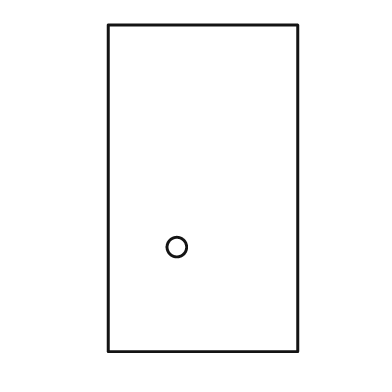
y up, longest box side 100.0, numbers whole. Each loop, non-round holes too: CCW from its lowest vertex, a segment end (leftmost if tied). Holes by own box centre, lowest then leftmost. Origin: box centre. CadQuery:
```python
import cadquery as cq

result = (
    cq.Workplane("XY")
    .moveTo(-29.0, -50.0)
    .lineTo(29.0, -50.0)
    .lineTo(29.0, 50.0)
    .lineTo(-29.0, 50.0)
    .close()
    .moveTo(-8.0, -18.0)
    .circle(3.0)
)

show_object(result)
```